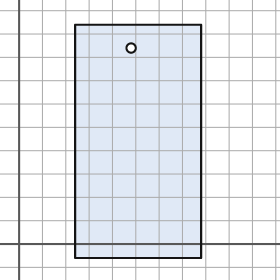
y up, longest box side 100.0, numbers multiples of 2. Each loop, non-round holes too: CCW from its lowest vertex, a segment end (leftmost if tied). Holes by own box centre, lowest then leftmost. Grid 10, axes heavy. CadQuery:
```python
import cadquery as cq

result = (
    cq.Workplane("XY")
    .moveTo(24.0, -6.0)
    .lineTo(78.0, -6.0)
    .lineTo(78.0, 94.0)
    .lineTo(24.0, 94.0)
    .close()
    .moveTo(48.0, 84.0)
    .circle(2.0)
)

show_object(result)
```